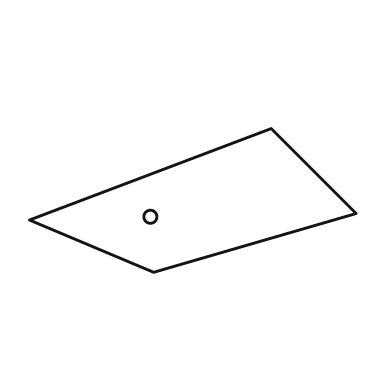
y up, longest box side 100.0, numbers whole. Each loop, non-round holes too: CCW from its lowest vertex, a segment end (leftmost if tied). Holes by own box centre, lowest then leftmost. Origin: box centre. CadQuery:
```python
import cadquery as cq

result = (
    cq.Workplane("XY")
    .moveTo(-12.0, -22.0)
    .lineTo(50.0, -4.0)
    .lineTo(24.0, 22.0)
    .lineTo(-50.0, -6.0)
    .close()
    .moveTo(-13.0, -5.0)
    .circle(2.0)
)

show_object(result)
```